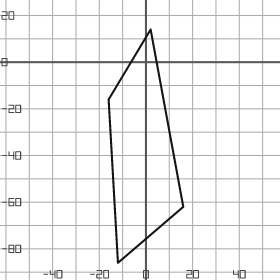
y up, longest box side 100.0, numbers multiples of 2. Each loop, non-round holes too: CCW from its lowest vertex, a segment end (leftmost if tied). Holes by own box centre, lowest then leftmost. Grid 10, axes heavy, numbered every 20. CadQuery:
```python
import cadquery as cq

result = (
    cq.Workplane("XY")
    .moveTo(-12.0, -86.0)
    .lineTo(16.0, -62.0)
    .lineTo(2.0, 14.0)
    .lineTo(-16.0, -16.0)
    .close()
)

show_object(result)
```